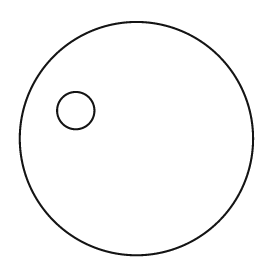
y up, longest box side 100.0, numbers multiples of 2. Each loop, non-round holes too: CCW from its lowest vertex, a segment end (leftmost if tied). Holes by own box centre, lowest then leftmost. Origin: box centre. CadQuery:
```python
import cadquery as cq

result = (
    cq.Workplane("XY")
    .moveTo(0.0, 0.0)
    .circle(50.0)
    .moveTo(-26.0, 12.0)
    .circle(8.0)
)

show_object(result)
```